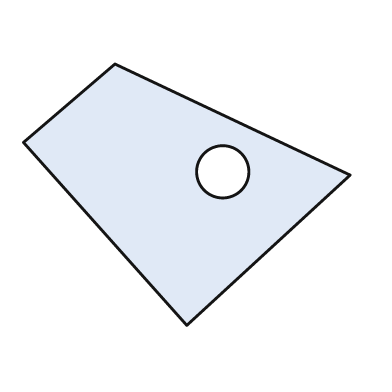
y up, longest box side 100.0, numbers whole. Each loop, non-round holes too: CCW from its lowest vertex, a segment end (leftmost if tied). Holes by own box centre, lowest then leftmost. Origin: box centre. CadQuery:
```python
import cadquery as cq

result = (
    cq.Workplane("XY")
    .moveTo(0.0, -40.0)
    .lineTo(50.0, 6.0)
    .lineTo(-22.0, 40.0)
    .lineTo(-50.0, 16.0)
    .close()
    .moveTo(11.0, 7.0)
    .circle(8.0)
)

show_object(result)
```